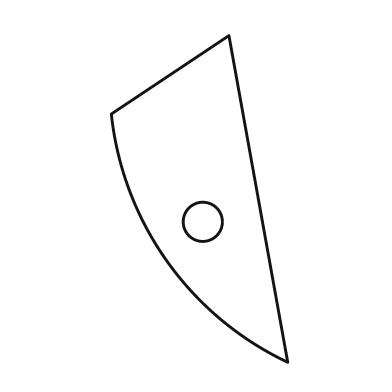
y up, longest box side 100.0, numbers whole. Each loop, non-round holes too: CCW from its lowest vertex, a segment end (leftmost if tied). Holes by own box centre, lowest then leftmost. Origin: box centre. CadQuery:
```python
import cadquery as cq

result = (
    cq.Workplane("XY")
    .moveTo(27.0, -50.0)
    .lineTo(9.0, 50.0)
    .lineTo(-27.0, 26.0)
    .threePointArc((-10.0, -19.0), (27.0, -50.0))
    .close()
    .moveTo(1.0, -7.0)
    .circle(6.0)
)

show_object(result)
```